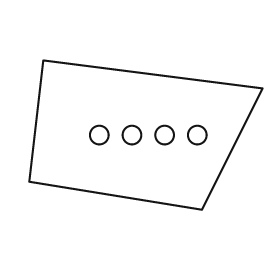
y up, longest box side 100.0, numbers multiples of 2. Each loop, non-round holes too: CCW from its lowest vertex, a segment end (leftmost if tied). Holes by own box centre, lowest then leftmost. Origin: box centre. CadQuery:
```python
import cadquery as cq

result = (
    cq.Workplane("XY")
    .moveTo(24.0, -32.0)
    .lineTo(50.0, 20.0)
    .lineTo(-44.0, 32.0)
    .lineTo(-50.0, -20.0)
    .close()
    .moveTo(-20.0, 0.0)
    .circle(4.0)
    .moveTo(-6.0, 0.0)
    .circle(4.0)
    .moveTo(8.0, 0.0)
    .circle(4.0)
    .moveTo(22.0, 0.0)
    .circle(4.0)
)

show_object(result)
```